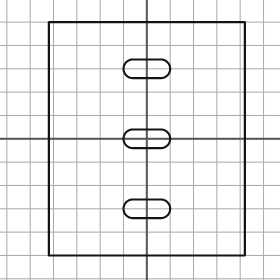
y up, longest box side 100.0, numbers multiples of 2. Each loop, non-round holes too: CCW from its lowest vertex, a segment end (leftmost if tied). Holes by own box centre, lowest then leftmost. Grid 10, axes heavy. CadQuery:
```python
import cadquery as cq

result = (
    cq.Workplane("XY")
    .moveTo(-42.0, -50.0)
    .lineTo(42.0, -50.0)
    .lineTo(42.0, 50.0)
    .lineTo(-42.0, 50.0)
    .close()
    .moveTo(-6.0, -34.0)
    .lineTo(6.0, -34.0)
    .threePointArc((10.0, -30.0), (6.0, -26.0))
    .lineTo(-6.0, -26.0)
    .threePointArc((-10.0, -30.0), (-6.0, -34.0))
    .close()
    .moveTo(-6.0, -4.0)
    .lineTo(6.0, -4.0)
    .threePointArc((10.0, 0.0), (6.0, 4.0))
    .lineTo(-6.0, 4.0)
    .threePointArc((-10.0, 0.0), (-6.0, -4.0))
    .close()
    .moveTo(-6.0, 26.0)
    .lineTo(6.0, 26.0)
    .threePointArc((10.0, 30.0), (6.0, 34.0))
    .lineTo(-6.0, 34.0)
    .threePointArc((-10.0, 30.0), (-6.0, 26.0))
    .close()
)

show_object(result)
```